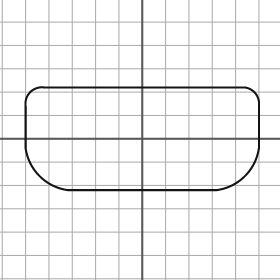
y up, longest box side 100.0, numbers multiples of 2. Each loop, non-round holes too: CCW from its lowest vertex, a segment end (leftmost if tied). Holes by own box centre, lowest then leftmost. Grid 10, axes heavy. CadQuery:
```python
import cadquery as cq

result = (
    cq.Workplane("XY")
    .moveTo(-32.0, -22.0)
    .lineTo(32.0, -22.0)
    .threePointArc((44.0, -16.0), (50.0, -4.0))
    .lineTo(50.0, 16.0)
    .threePointArc((48.0, 20.0), (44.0, 22.0))
    .lineTo(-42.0, 22.0)
    .threePointArc((-48.0, 20.0), (-50.0, 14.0))
    .lineTo(-50.0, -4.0)
    .threePointArc((-44.0, -16.0), (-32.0, -22.0))
    .close()
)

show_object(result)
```